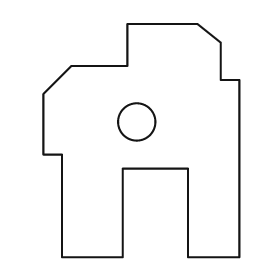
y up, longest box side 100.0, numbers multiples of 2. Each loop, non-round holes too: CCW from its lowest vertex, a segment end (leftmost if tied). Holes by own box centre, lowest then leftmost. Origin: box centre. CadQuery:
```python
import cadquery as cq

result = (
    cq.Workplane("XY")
    .moveTo(-34.0, -50.0)
    .lineTo(-8.0, -50.0)
    .lineTo(-8.0, -12.0)
    .lineTo(20.0, -12.0)
    .lineTo(20.0, -50.0)
    .lineTo(42.0, -50.0)
    .lineTo(42.0, 26.0)
    .lineTo(34.0, 26.0)
    .lineTo(34.0, 42.0)
    .lineTo(24.0, 50.0)
    .lineTo(-6.0, 50.0)
    .lineTo(-6.0, 32.0)
    .lineTo(-30.0, 32.0)
    .lineTo(-42.0, 20.0)
    .lineTo(-42.0, -6.0)
    .lineTo(-34.0, -6.0)
    .close()
    .moveTo(-2.0, 8.0)
    .circle(8.0)
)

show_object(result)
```